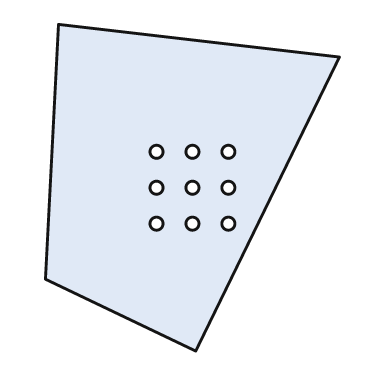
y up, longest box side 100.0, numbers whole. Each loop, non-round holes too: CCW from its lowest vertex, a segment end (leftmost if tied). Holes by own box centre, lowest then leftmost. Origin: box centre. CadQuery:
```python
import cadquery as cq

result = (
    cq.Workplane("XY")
    .moveTo(1.0, -50.0)
    .lineTo(45.0, 40.0)
    .lineTo(-41.0, 50.0)
    .lineTo(-45.0, -28.0)
    .close()
    .moveTo(-11.0, -11.0)
    .circle(2.0)
    .moveTo(0.0, -11.0)
    .circle(2.0)
    .moveTo(11.0, -11.0)
    .circle(2.0)
    .moveTo(-11.0, 0.0)
    .circle(2.0)
    .moveTo(0.0, 0.0)
    .circle(2.0)
    .moveTo(11.0, 0.0)
    .circle(2.0)
    .moveTo(-11.0, 11.0)
    .circle(2.0)
    .moveTo(0.0, 11.0)
    .circle(2.0)
    .moveTo(11.0, 11.0)
    .circle(2.0)
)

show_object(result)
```